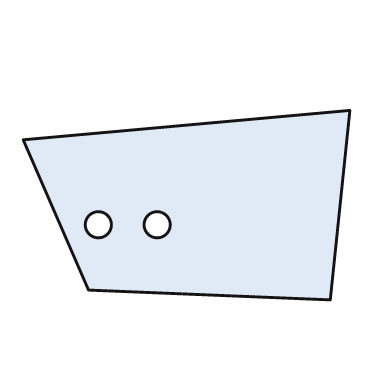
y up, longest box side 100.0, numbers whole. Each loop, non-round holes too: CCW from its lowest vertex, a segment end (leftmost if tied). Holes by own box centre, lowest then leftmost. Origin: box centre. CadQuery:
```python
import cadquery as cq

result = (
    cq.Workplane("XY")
    .moveTo(44.0, -29.0)
    .lineTo(50.0, 29.0)
    .lineTo(-50.0, 20.0)
    .lineTo(-30.0, -26.0)
    .close()
    .moveTo(-27.0, -6.0)
    .circle(4.0)
    .moveTo(-9.0, -6.0)
    .circle(4.0)
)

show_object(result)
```